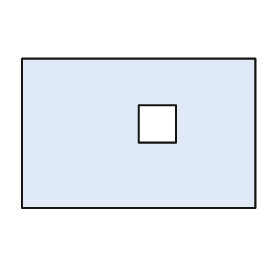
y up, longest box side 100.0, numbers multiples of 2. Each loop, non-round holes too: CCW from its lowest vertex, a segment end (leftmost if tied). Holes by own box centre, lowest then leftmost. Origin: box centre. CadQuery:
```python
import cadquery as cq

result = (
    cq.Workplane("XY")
    .moveTo(-50.0, -32.0)
    .lineTo(50.0, -32.0)
    .lineTo(50.0, 32.0)
    .lineTo(-50.0, 32.0)
    .close()
    .moveTo(0.0, -4.0)
    .lineTo(16.0, -4.0)
    .lineTo(16.0, 12.0)
    .lineTo(0.0, 12.0)
    .close()
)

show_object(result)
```